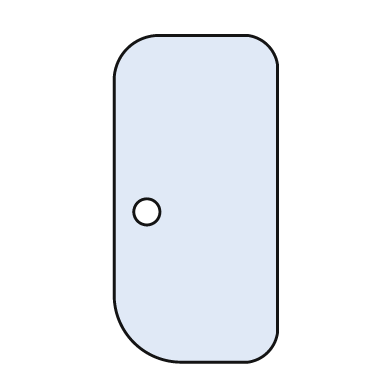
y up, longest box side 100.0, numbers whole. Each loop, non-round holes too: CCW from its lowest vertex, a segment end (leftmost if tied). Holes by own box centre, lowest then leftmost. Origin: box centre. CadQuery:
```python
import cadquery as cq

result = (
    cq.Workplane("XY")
    .moveTo(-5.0, -50.0)
    .lineTo(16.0, -50.0)
    .threePointArc((22.0, -47.0), (25.0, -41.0))
    .lineTo(25.0, 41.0)
    .threePointArc((22.0, 47.0), (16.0, 50.0))
    .lineTo(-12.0, 50.0)
    .threePointArc((-21.0, 46.0), (-25.0, 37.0))
    .lineTo(-25.0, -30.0)
    .threePointArc((-19.0, -44.0), (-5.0, -50.0))
    .close()
    .moveTo(-15.0, -4.0)
    .circle(4.0)
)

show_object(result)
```